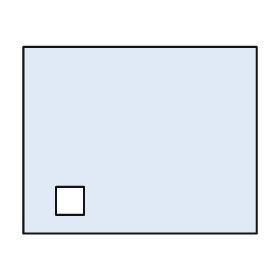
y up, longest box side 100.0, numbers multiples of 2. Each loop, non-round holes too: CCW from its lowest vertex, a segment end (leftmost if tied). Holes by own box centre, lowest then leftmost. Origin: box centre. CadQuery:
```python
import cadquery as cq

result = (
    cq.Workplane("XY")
    .moveTo(-50.0, -40.0)
    .lineTo(50.0, -40.0)
    .lineTo(50.0, 40.0)
    .lineTo(-50.0, 40.0)
    .close()
    .moveTo(-36.0, -32.0)
    .lineTo(-24.0, -32.0)
    .lineTo(-24.0, -20.0)
    .lineTo(-36.0, -20.0)
    .close()
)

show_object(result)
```